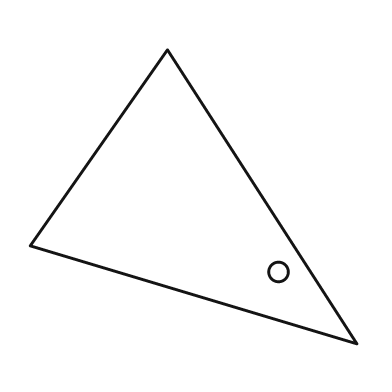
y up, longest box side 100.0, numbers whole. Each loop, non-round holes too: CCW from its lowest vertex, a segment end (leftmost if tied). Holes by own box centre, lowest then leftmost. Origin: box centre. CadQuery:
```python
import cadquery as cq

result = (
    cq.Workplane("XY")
    .moveTo(50.0, -45.0)
    .lineTo(-8.0, 45.0)
    .lineTo(-50.0, -15.0)
    .close()
    .moveTo(26.0, -23.0)
    .circle(3.0)
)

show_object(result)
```